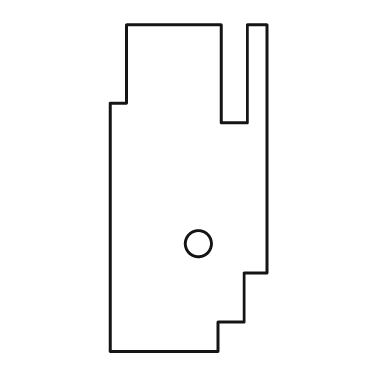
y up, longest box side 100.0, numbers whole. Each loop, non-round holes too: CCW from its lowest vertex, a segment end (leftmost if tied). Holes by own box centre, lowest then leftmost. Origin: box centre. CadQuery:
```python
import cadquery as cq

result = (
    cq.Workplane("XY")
    .moveTo(-24.0, -50.0)
    .lineTo(9.0, -50.0)
    .lineTo(9.0, -41.0)
    .lineTo(17.0, -41.0)
    .lineTo(17.0, -26.0)
    .lineTo(24.0, -26.0)
    .lineTo(24.0, 50.0)
    .lineTo(18.0, 50.0)
    .lineTo(18.0, 20.0)
    .lineTo(10.0, 20.0)
    .lineTo(10.0, 50.0)
    .lineTo(-19.0, 50.0)
    .lineTo(-19.0, 26.0)
    .lineTo(-24.0, 26.0)
    .close()
    .moveTo(3.0, -17.0)
    .circle(4.0)
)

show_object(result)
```